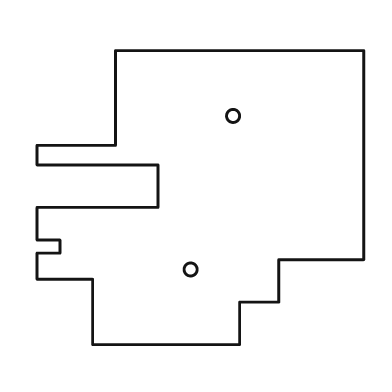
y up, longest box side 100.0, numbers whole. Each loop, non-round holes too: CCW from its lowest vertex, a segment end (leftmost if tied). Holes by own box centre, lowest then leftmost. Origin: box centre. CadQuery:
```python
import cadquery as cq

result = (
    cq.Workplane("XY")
    .moveTo(-33.0, -45.0)
    .lineTo(12.0, -45.0)
    .lineTo(12.0, -32.0)
    .lineTo(24.0, -32.0)
    .lineTo(24.0, -19.0)
    .lineTo(50.0, -19.0)
    .lineTo(50.0, 45.0)
    .lineTo(-26.0, 45.0)
    .lineTo(-26.0, 16.0)
    .lineTo(-50.0, 16.0)
    .lineTo(-50.0, 10.0)
    .lineTo(-13.0, 10.0)
    .lineTo(-13.0, -3.0)
    .lineTo(-50.0, -3.0)
    .lineTo(-50.0, -13.0)
    .lineTo(-43.0, -13.0)
    .lineTo(-43.0, -17.0)
    .lineTo(-50.0, -17.0)
    .lineTo(-50.0, -25.0)
    .lineTo(-33.0, -25.0)
    .close()
    .moveTo(-3.0, -22.0)
    .circle(2.0)
    .moveTo(10.0, 25.0)
    .circle(2.0)
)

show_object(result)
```